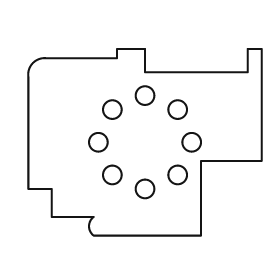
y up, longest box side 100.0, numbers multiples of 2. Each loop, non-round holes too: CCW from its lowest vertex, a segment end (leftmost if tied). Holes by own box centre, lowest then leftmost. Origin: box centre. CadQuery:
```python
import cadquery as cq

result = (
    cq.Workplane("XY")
    .moveTo(-22.0, -40.0)
    .lineTo(24.0, -40.0)
    .lineTo(24.0, -8.0)
    .lineTo(50.0, -8.0)
    .lineTo(50.0, 40.0)
    .lineTo(44.0, 40.0)
    .lineTo(44.0, 30.0)
    .lineTo(0.0, 30.0)
    .lineTo(0.0, 40.0)
    .lineTo(-12.0, 40.0)
    .lineTo(-12.0, 36.0)
    .lineTo(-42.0, 36.0)
    .threePointArc((-48.0, 34.0), (-50.0, 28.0))
    .lineTo(-50.0, -20.0)
    .lineTo(-40.0, -20.0)
    .lineTo(-40.0, -32.0)
    .lineTo(-22.0, -32.0)
    .threePointArc((-24.0, -36.0), (-22.0, -40.0))
    .close()
    .moveTo(0.0, -20.0)
    .circle(4.0)
    .moveTo(-14.0, -14.0)
    .circle(4.0)
    .moveTo(14.0, -14.0)
    .circle(4.0)
    .moveTo(-20.0, 0.0)
    .circle(4.0)
    .moveTo(20.0, 0.0)
    .circle(4.0)
    .moveTo(-14.0, 14.0)
    .circle(4.0)
    .moveTo(14.0, 14.0)
    .circle(4.0)
    .moveTo(0.0, 20.0)
    .circle(4.0)
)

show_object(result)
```